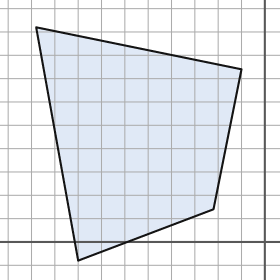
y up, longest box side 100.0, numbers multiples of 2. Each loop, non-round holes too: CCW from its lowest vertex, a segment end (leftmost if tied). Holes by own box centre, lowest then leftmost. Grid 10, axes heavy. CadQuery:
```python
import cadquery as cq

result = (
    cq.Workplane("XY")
    .moveTo(-80.0, -8.0)
    .lineTo(-22.0, 14.0)
    .lineTo(-10.0, 74.0)
    .lineTo(-98.0, 92.0)
    .close()
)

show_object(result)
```